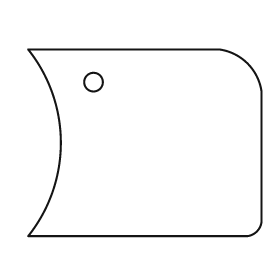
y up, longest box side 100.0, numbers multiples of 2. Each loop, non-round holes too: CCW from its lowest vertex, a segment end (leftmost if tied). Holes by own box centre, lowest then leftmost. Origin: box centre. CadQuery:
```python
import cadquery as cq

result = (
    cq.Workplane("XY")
    .moveTo(-50.0, -40.0)
    .lineTo(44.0, -40.0)
    .threePointArc((48.0, -38.0), (50.0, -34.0))
    .lineTo(50.0, 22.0)
    .threePointArc((44.0, 34.0), (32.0, 40.0))
    .lineTo(-50.0, 40.0)
    .threePointArc((-36.0, 0.0), (-50.0, -40.0))
    .close()
    .moveTo(-22.0, 26.0)
    .circle(4.0)
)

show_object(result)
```